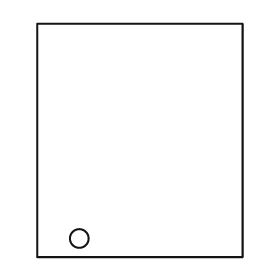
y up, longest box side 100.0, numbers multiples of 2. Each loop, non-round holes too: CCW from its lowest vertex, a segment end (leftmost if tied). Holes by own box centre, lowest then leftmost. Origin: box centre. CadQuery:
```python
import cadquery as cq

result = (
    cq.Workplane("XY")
    .moveTo(-44.0, -50.0)
    .lineTo(44.0, -50.0)
    .lineTo(44.0, 50.0)
    .lineTo(-44.0, 50.0)
    .close()
    .moveTo(-26.0, -42.0)
    .circle(4.0)
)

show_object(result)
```